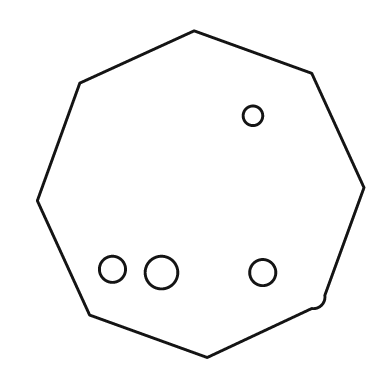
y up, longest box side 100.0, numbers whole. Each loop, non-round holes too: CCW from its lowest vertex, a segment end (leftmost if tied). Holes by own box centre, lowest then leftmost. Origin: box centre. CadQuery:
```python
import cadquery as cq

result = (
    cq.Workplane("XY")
    .moveTo(2.0, -50.0)
    .lineTo(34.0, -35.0)
    .threePointArc((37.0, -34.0), (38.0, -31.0))
    .lineTo(50.0, 2.0)
    .lineTo(34.0, 37.0)
    .lineTo(-2.0, 50.0)
    .lineTo(-37.0, 34.0)
    .lineTo(-50.0, -2.0)
    .lineTo(-34.0, -37.0)
    .close()
    .moveTo(-12.0, -24.0)
    .circle(5.0)
    .moveTo(19.0, -24.0)
    .circle(4.0)
    .moveTo(-27.0, -23.0)
    .circle(4.0)
    .moveTo(16.0, 24.0)
    .circle(3.0)
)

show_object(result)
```